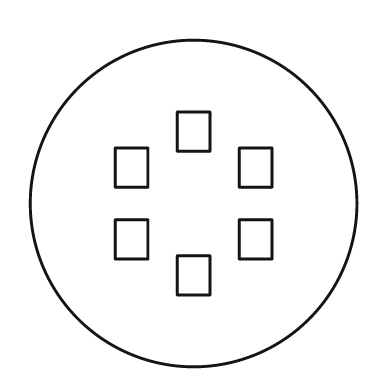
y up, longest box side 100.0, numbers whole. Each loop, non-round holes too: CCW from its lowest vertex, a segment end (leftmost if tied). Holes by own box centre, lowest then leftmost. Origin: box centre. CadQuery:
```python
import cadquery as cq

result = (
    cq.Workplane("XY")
    .moveTo(0.0, 0.0)
    .circle(50.0)
    .moveTo(-5.0, -28.0)
    .lineTo(5.0, -28.0)
    .lineTo(5.0, -16.0)
    .lineTo(-5.0, -16.0)
    .close()
    .moveTo(-24.0, -17.0)
    .lineTo(-14.0, -17.0)
    .lineTo(-14.0, -5.0)
    .lineTo(-24.0, -5.0)
    .close()
    .moveTo(14.0, -17.0)
    .lineTo(24.0, -17.0)
    .lineTo(24.0, -5.0)
    .lineTo(14.0, -5.0)
    .close()
    .moveTo(-24.0, 5.0)
    .lineTo(-14.0, 5.0)
    .lineTo(-14.0, 17.0)
    .lineTo(-24.0, 17.0)
    .close()
    .moveTo(14.0, 5.0)
    .lineTo(24.0, 5.0)
    .lineTo(24.0, 17.0)
    .lineTo(14.0, 17.0)
    .close()
    .moveTo(-5.0, 16.0)
    .lineTo(5.0, 16.0)
    .lineTo(5.0, 28.0)
    .lineTo(-5.0, 28.0)
    .close()
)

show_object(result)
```